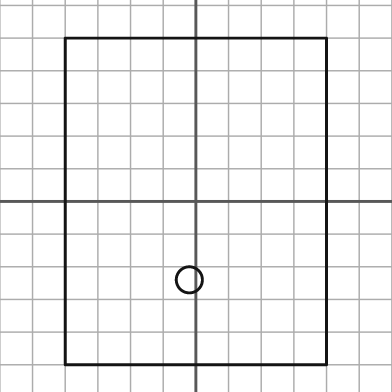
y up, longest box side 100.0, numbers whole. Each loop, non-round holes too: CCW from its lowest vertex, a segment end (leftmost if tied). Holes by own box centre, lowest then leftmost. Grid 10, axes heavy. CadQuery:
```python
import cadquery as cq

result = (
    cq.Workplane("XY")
    .moveTo(-40.0, -50.0)
    .lineTo(40.0, -50.0)
    .lineTo(40.0, 50.0)
    .lineTo(-40.0, 50.0)
    .close()
    .moveTo(-2.0, -24.0)
    .circle(4.0)
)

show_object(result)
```